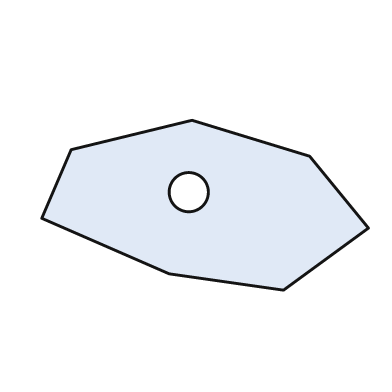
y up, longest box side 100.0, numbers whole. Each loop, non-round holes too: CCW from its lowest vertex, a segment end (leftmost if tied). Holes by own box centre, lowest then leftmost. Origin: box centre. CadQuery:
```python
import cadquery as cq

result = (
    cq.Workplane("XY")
    .moveTo(24.0, -26.0)
    .lineTo(50.0, -7.0)
    .lineTo(32.0, 15.0)
    .lineTo(-4.0, 26.0)
    .lineTo(-41.0, 17.0)
    .lineTo(-50.0, -4.0)
    .lineTo(-11.0, -21.0)
    .close()
    .moveTo(-5.0, 4.0)
    .circle(6.0)
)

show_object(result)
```